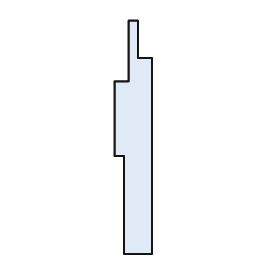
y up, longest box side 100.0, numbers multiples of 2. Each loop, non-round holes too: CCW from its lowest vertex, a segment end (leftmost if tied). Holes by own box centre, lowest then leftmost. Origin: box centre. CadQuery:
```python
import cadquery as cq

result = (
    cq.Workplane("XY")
    .moveTo(-4.0, -50.0)
    .lineTo(8.0, -50.0)
    .lineTo(8.0, 34.0)
    .lineTo(2.0, 34.0)
    .lineTo(2.0, 50.0)
    .lineTo(-2.0, 50.0)
    .lineTo(-2.0, 24.0)
    .lineTo(-8.0, 24.0)
    .lineTo(-8.0, -8.0)
    .lineTo(-4.0, -8.0)
    .close()
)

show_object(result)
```